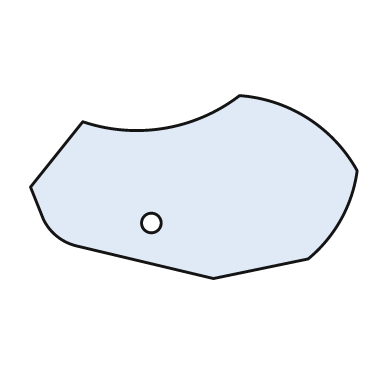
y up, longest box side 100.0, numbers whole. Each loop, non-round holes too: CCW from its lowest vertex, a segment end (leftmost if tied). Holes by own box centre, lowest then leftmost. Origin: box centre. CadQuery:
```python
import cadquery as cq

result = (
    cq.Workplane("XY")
    .moveTo(6.0, -28.0)
    .lineTo(35.0, -22.0)
    .threePointArc((45.0, -10.0), (50.0, 5.0))
    .threePointArc((35.0, 21.0), (14.0, 28.0))
    .threePointArc((-9.0, 18.0), (-34.0, 20.0))
    .lineTo(-50.0, 0.0)
    .lineTo(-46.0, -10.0)
    .threePointArc((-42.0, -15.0), (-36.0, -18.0))
    .close()
    .moveTo(-13.0, -11.0)
    .circle(3.0)
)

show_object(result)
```